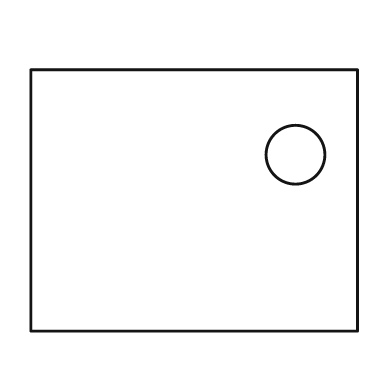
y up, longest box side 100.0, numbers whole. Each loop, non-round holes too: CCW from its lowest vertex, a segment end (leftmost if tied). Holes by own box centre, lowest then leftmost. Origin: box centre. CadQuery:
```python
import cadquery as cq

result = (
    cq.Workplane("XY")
    .moveTo(-50.0, -40.0)
    .lineTo(50.0, -40.0)
    .lineTo(50.0, 40.0)
    .lineTo(-50.0, 40.0)
    .close()
    .moveTo(31.0, 14.0)
    .circle(9.0)
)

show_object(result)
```